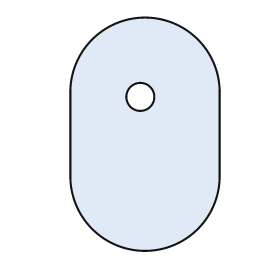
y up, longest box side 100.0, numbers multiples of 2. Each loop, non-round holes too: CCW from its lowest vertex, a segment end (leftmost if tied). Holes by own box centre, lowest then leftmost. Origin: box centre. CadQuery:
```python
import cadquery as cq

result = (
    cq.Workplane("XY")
    .moveTo(-32.0, -18.0)
    .threePointArc((0.0, -50.0), (32.0, -18.0))
    .lineTo(32.0, 18.0)
    .threePointArc((0.0, 50.0), (-32.0, 18.0))
    .close()
    .moveTo(-2.0, 16.0)
    .circle(6.0)
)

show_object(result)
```